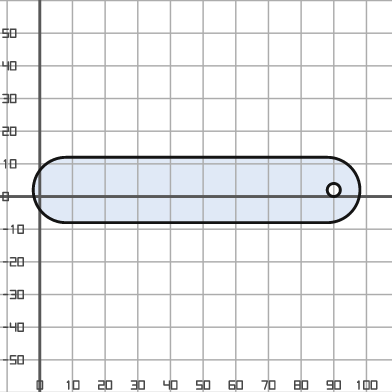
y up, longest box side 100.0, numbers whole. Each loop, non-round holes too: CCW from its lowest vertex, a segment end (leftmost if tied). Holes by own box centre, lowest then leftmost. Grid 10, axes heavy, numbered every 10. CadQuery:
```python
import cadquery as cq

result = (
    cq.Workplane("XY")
    .moveTo(8.0, -8.0)
    .lineTo(88.0, -8.0)
    .threePointArc((98.0, 2.0), (88.0, 12.0))
    .lineTo(8.0, 12.0)
    .threePointArc((-2.0, 2.0), (8.0, -8.0))
    .close()
    .moveTo(90.0, 2.0)
    .circle(2.0)
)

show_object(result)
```